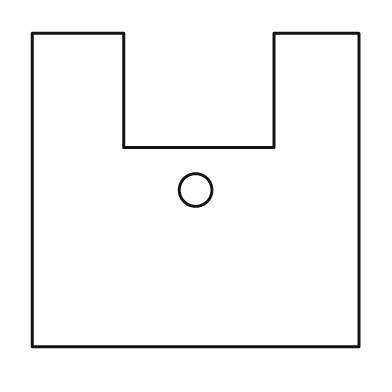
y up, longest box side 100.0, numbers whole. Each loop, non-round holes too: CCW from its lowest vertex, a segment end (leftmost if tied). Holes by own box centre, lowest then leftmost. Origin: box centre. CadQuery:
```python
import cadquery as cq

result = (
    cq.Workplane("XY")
    .moveTo(-50.0, -48.0)
    .lineTo(50.0, -48.0)
    .lineTo(50.0, 48.0)
    .lineTo(24.0, 48.0)
    .lineTo(24.0, 13.0)
    .lineTo(-22.0, 13.0)
    .lineTo(-22.0, 48.0)
    .lineTo(-50.0, 48.0)
    .close()
    .moveTo(0.0, 0.0)
    .circle(5.0)
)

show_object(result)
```